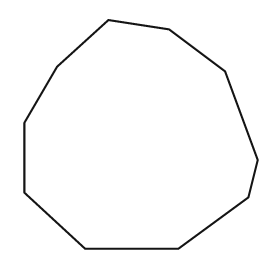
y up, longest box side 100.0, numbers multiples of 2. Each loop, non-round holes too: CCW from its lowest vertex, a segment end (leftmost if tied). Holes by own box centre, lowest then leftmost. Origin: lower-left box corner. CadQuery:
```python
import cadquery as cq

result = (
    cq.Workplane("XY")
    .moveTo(26.0, 0.0)
    .lineTo(66.0, 0.0)
    .lineTo(96.0, 22.0)
    .lineTo(100.0, 38.0)
    .lineTo(86.0, 76.0)
    .lineTo(62.0, 94.0)
    .lineTo(36.0, 98.0)
    .lineTo(14.0, 78.0)
    .lineTo(0.0, 54.0)
    .lineTo(0.0, 24.0)
    .close()
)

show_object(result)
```